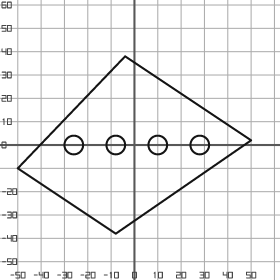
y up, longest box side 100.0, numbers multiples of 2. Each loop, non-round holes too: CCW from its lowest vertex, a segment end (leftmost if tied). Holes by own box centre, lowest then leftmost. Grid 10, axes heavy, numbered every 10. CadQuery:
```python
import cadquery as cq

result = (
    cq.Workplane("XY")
    .moveTo(-8.0, -38.0)
    .lineTo(50.0, 2.0)
    .lineTo(-4.0, 38.0)
    .lineTo(-50.0, -10.0)
    .close()
    .moveTo(-26.0, 0.0)
    .circle(4.0)
    .moveTo(-8.0, 0.0)
    .circle(4.0)
    .moveTo(10.0, 0.0)
    .circle(4.0)
    .moveTo(28.0, 0.0)
    .circle(4.0)
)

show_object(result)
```